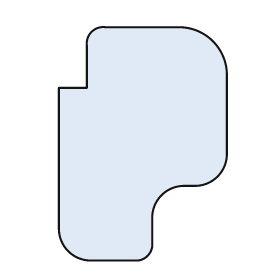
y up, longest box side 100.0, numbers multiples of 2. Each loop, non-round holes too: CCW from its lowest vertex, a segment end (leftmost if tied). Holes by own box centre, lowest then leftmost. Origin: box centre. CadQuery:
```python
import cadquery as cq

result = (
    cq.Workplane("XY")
    .moveTo(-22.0, -50.0)
    .lineTo(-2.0, -50.0)
    .threePointArc((2.0, -48.0), (4.0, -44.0))
    .lineTo(4.0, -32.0)
    .threePointArc((8.0, -22.0), (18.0, -18.0))
    .lineTo(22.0, -18.0)
    .threePointArc((32.0, -14.0), (36.0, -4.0))
    .lineTo(36.0, 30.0)
    .threePointArc((30.0, 44.0), (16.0, 50.0))
    .lineTo(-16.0, 50.0)
    .threePointArc((-22.0, 48.0), (-24.0, 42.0))
    .lineTo(-24.0, 24.0)
    .lineTo(-36.0, 24.0)
    .lineTo(-36.0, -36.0)
    .threePointArc((-32.0, -46.0), (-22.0, -50.0))
    .close()
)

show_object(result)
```